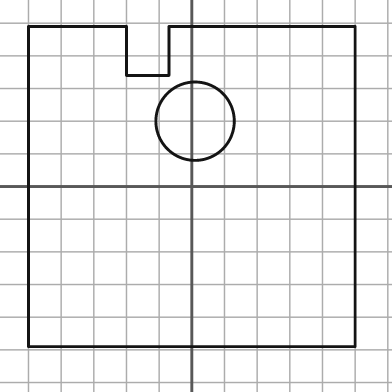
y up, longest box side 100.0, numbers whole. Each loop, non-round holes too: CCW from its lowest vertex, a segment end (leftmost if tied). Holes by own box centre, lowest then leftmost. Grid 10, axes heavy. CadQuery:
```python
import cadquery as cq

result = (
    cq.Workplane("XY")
    .moveTo(-50.0, -49.0)
    .lineTo(50.0, -49.0)
    .lineTo(50.0, 49.0)
    .lineTo(-7.0, 49.0)
    .lineTo(-7.0, 34.0)
    .lineTo(-20.0, 34.0)
    .lineTo(-20.0, 49.0)
    .lineTo(-50.0, 49.0)
    .close()
    .moveTo(1.0, 20.0)
    .circle(12.0)
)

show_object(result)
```